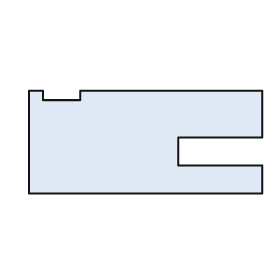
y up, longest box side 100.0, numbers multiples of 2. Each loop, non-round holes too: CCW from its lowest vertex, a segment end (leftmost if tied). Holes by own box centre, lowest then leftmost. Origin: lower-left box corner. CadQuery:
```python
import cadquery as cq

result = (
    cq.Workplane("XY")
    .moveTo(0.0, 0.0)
    .lineTo(100.0, 0.0)
    .lineTo(100.0, 12.0)
    .lineTo(64.0, 12.0)
    .lineTo(64.0, 24.0)
    .lineTo(100.0, 24.0)
    .lineTo(100.0, 44.0)
    .lineTo(22.0, 44.0)
    .lineTo(22.0, 40.0)
    .lineTo(6.0, 40.0)
    .lineTo(6.0, 44.0)
    .lineTo(0.0, 44.0)
    .close()
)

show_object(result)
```